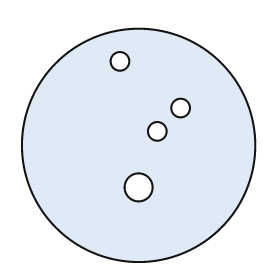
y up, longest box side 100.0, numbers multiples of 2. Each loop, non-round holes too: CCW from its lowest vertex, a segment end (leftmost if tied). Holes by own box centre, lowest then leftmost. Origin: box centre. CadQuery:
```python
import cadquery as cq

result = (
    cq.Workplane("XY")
    .moveTo(0.0, 0.0)
    .circle(50.0)
    .moveTo(0.0, -18.0)
    .circle(6.0)
    .moveTo(8.0, 6.0)
    .circle(4.0)
    .moveTo(18.0, 16.0)
    .circle(4.0)
    .moveTo(-8.0, 36.0)
    .circle(4.0)
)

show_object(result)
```